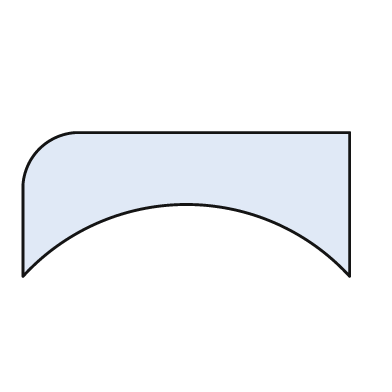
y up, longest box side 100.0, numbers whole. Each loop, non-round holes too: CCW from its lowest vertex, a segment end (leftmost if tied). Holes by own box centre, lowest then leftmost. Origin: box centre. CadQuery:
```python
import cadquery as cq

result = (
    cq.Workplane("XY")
    .moveTo(-50.0, -22.0)
    .threePointArc((0.0, 0.0), (50.0, -22.0))
    .lineTo(50.0, 22.0)
    .lineTo(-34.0, 22.0)
    .threePointArc((-45.0, 17.0), (-50.0, 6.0))
    .close()
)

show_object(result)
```